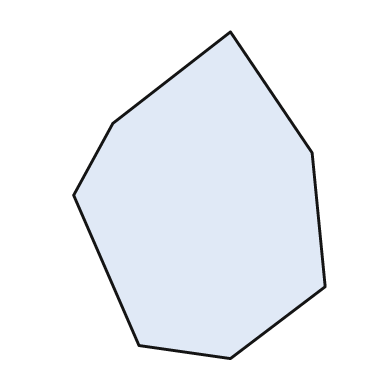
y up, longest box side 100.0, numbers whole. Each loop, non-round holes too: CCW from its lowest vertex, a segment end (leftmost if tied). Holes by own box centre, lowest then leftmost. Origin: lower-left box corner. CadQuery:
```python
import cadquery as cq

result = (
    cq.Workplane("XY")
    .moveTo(48.0, 0.0)
    .lineTo(77.0, 22.0)
    .lineTo(73.0, 63.0)
    .lineTo(48.0, 100.0)
    .lineTo(12.0, 72.0)
    .lineTo(0.0, 50.0)
    .lineTo(20.0, 4.0)
    .close()
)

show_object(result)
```